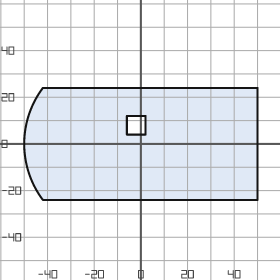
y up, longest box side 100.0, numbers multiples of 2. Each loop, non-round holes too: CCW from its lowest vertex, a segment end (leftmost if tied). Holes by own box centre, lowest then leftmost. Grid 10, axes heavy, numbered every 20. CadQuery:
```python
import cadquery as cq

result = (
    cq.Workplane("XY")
    .moveTo(-42.0, -24.0)
    .lineTo(50.0, -24.0)
    .lineTo(50.0, 24.0)
    .lineTo(-42.0, 24.0)
    .threePointArc((-50.0, 0.0), (-42.0, -24.0))
    .close()
    .moveTo(-6.0, 4.0)
    .lineTo(2.0, 4.0)
    .lineTo(2.0, 12.0)
    .lineTo(-6.0, 12.0)
    .close()
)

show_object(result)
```